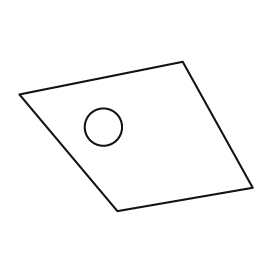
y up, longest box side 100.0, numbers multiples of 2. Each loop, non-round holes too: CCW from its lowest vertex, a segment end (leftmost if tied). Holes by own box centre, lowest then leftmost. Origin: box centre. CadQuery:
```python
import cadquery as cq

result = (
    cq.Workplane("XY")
    .moveTo(-8.0, -32.0)
    .lineTo(50.0, -22.0)
    .lineTo(20.0, 32.0)
    .lineTo(-50.0, 18.0)
    .close()
    .moveTo(-14.0, 4.0)
    .circle(8.0)
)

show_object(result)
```